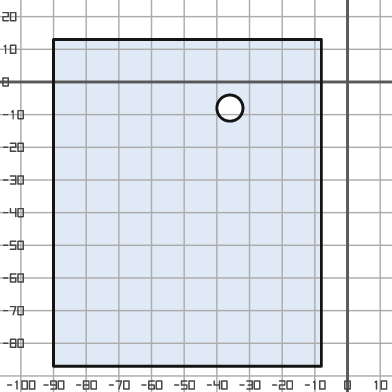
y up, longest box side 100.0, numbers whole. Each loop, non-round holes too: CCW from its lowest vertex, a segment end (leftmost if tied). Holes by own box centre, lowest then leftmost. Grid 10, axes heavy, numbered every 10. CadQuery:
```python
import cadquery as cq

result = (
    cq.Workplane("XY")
    .moveTo(-90.0, -87.0)
    .lineTo(-8.0, -87.0)
    .lineTo(-8.0, 13.0)
    .lineTo(-90.0, 13.0)
    .close()
    .moveTo(-36.0, -8.0)
    .circle(4.0)
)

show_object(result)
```